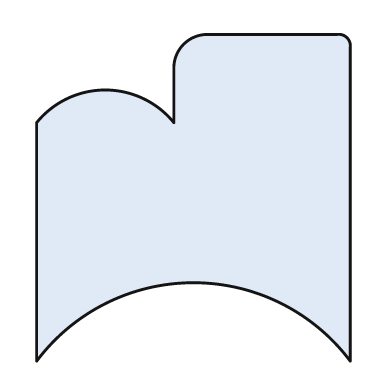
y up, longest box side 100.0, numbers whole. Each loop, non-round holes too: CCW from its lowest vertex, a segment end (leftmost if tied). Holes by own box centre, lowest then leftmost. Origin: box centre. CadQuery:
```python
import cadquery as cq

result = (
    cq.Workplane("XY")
    .moveTo(-48.0, -50.0)
    .threePointArc((0.0, -26.0), (48.0, -50.0))
    .lineTo(48.0, 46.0)
    .threePointArc((47.0, 49.0), (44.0, 50.0))
    .lineTo(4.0, 50.0)
    .threePointArc((-3.0, 47.0), (-6.0, 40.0))
    .lineTo(-6.0, 23.0)
    .threePointArc((-27.0, 33.0), (-48.0, 23.0))
    .close()
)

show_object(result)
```